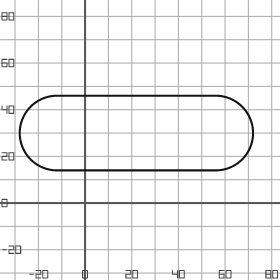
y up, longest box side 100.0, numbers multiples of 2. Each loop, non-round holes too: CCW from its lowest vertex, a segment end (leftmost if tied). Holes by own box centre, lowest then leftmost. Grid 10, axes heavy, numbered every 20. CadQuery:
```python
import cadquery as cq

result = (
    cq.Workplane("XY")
    .moveTo(-12.0, 14.0)
    .lineTo(56.0, 14.0)
    .threePointArc((72.0, 30.0), (56.0, 46.0))
    .lineTo(-12.0, 46.0)
    .threePointArc((-28.0, 30.0), (-12.0, 14.0))
    .close()
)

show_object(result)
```